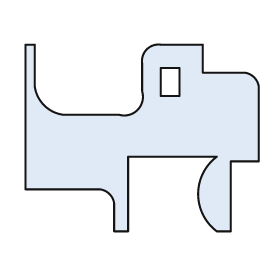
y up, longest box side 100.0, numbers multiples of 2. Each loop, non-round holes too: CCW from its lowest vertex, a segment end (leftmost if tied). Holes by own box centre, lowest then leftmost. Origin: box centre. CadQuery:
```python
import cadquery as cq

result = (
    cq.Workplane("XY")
    .moveTo(-12.0, -40.0)
    .lineTo(-6.0, -40.0)
    .lineTo(-6.0, -8.0)
    .lineTo(32.0, -8.0)
    .threePointArc((24.0, -24.0), (32.0, -40.0))
    .lineTo(38.0, -40.0)
    .lineTo(38.0, -10.0)
    .lineTo(50.0, -10.0)
    .lineTo(50.0, 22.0)
    .threePointArc((48.0, 26.0), (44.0, 28.0))
    .lineTo(26.0, 28.0)
    .lineTo(26.0, 40.0)
    .lineTo(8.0, 40.0)
    .threePointArc((2.0, 38.0), (0.0, 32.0))
    .lineTo(0.0, 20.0)
    .threePointArc((-2.0, 12.0), (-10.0, 10.0))
    .lineTo(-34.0, 10.0)
    .threePointArc((-42.0, 14.0), (-46.0, 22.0))
    .lineTo(-46.0, 40.0)
    .lineTo(-50.0, 40.0)
    .lineTo(-50.0, -22.0)
    .lineTo(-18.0, -22.0)
    .threePointArc((-14.0, -24.0), (-12.0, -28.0))
    .close()
    .moveTo(8.0, 18.0)
    .lineTo(16.0, 18.0)
    .lineTo(16.0, 30.0)
    .lineTo(8.0, 30.0)
    .close()
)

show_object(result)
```